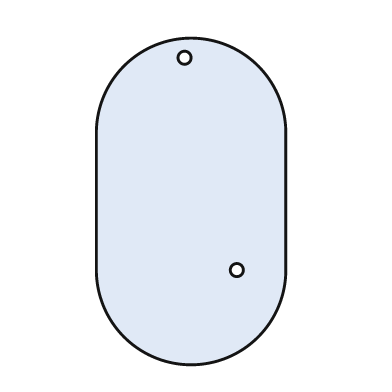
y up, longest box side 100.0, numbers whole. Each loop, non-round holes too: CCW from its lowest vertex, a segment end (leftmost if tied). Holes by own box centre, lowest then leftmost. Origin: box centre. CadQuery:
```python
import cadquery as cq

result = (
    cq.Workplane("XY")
    .moveTo(-29.0, -21.0)
    .threePointArc((0.0, -50.0), (29.0, -21.0))
    .lineTo(29.0, 21.0)
    .threePointArc((0.0, 50.0), (-29.0, 21.0))
    .close()
    .moveTo(14.0, -21.0)
    .circle(2.0)
    .moveTo(-2.0, 44.0)
    .circle(2.0)
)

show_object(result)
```